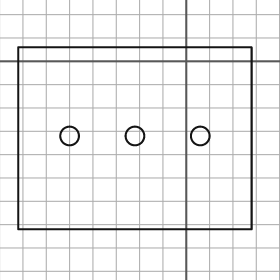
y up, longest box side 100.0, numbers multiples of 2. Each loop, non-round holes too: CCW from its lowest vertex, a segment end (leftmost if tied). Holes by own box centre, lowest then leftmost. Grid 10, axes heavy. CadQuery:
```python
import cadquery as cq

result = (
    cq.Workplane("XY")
    .moveTo(-72.0, -72.0)
    .lineTo(28.0, -72.0)
    .lineTo(28.0, 6.0)
    .lineTo(-72.0, 6.0)
    .close()
    .moveTo(-50.0, -32.0)
    .circle(4.0)
    .moveTo(-22.0, -32.0)
    .circle(4.0)
    .moveTo(6.0, -32.0)
    .circle(4.0)
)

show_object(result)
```